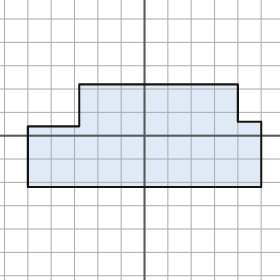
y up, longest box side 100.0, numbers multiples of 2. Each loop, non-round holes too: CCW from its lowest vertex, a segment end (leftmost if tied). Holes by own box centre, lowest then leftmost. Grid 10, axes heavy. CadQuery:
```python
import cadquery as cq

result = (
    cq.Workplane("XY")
    .moveTo(-50.0, -22.0)
    .lineTo(50.0, -22.0)
    .lineTo(50.0, 6.0)
    .lineTo(40.0, 6.0)
    .lineTo(40.0, 22.0)
    .lineTo(-28.0, 22.0)
    .lineTo(-28.0, 4.0)
    .lineTo(-50.0, 4.0)
    .close()
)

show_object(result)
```